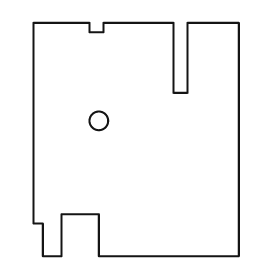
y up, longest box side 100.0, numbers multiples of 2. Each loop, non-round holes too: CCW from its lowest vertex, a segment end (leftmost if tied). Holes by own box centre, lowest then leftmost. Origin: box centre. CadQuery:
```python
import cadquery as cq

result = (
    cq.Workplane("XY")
    .moveTo(-40.0, -50.0)
    .lineTo(-32.0, -50.0)
    .lineTo(-32.0, -32.0)
    .lineTo(-16.0, -32.0)
    .lineTo(-16.0, -50.0)
    .lineTo(44.0, -50.0)
    .lineTo(44.0, 50.0)
    .lineTo(22.0, 50.0)
    .lineTo(22.0, 20.0)
    .lineTo(16.0, 20.0)
    .lineTo(16.0, 50.0)
    .lineTo(-14.0, 50.0)
    .lineTo(-14.0, 46.0)
    .lineTo(-20.0, 46.0)
    .lineTo(-20.0, 50.0)
    .lineTo(-44.0, 50.0)
    .lineTo(-44.0, -36.0)
    .lineTo(-40.0, -36.0)
    .close()
    .moveTo(-16.0, 8.0)
    .circle(4.0)
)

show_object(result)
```